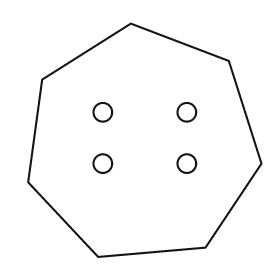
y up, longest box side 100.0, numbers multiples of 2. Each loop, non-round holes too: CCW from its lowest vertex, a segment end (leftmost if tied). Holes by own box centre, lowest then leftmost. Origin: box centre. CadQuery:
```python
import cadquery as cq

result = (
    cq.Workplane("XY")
    .moveTo(-20.0, -50.0)
    .lineTo(26.0, -46.0)
    .lineTo(50.0, -10.0)
    .lineTo(36.0, 34.0)
    .lineTo(-6.0, 50.0)
    .lineTo(-44.0, 26.0)
    .lineTo(-50.0, -18.0)
    .close()
    .moveTo(-18.0, -10.0)
    .circle(4.0)
    .moveTo(18.0, -10.0)
    .circle(4.0)
    .moveTo(-18.0, 12.0)
    .circle(4.0)
    .moveTo(18.0, 12.0)
    .circle(4.0)
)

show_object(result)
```